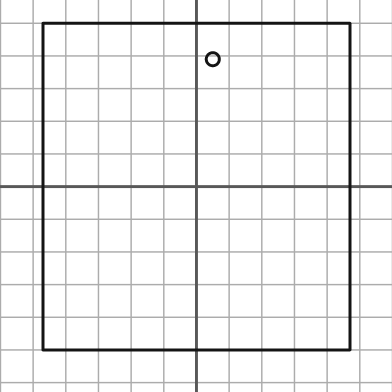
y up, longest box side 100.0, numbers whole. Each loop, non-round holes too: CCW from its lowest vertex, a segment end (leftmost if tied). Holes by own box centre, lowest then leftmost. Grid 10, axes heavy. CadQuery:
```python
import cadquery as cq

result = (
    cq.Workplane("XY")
    .moveTo(-47.0, -50.0)
    .lineTo(47.0, -50.0)
    .lineTo(47.0, 50.0)
    .lineTo(-47.0, 50.0)
    .close()
    .moveTo(5.0, 39.0)
    .circle(2.0)
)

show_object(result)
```